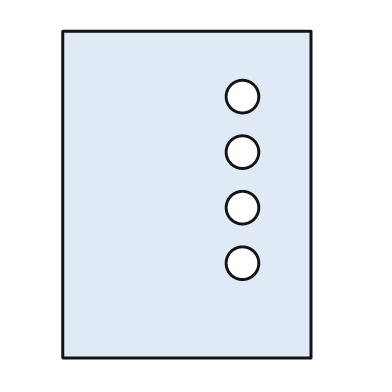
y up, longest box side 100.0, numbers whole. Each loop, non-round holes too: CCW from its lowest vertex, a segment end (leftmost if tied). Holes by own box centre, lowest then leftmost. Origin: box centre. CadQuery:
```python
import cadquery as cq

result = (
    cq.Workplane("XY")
    .moveTo(-38.0, -50.0)
    .lineTo(38.0, -50.0)
    .lineTo(38.0, 50.0)
    .lineTo(-38.0, 50.0)
    .close()
    .moveTo(17.0, -21.0)
    .circle(5.0)
    .moveTo(17.0, -4.0)
    .circle(5.0)
    .moveTo(17.0, 13.0)
    .circle(5.0)
    .moveTo(17.0, 30.0)
    .circle(5.0)
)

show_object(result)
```